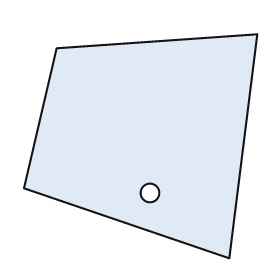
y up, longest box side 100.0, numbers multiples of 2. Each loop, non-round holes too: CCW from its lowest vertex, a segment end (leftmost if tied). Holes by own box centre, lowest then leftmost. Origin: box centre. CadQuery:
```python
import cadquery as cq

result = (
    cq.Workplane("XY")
    .moveTo(38.0, -48.0)
    .lineTo(50.0, 48.0)
    .lineTo(-36.0, 42.0)
    .lineTo(-50.0, -18.0)
    .close()
    .moveTo(4.0, -20.0)
    .circle(4.0)
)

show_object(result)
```